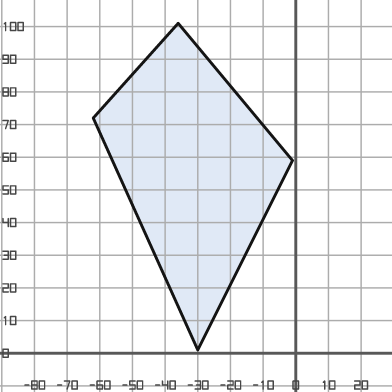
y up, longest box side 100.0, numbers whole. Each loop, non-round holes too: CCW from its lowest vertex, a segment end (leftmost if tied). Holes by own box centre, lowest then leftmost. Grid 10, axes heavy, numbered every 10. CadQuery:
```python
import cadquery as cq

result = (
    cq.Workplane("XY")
    .moveTo(-30.0, 1.0)
    .lineTo(-1.0, 59.0)
    .lineTo(-36.0, 101.0)
    .lineTo(-62.0, 72.0)
    .close()
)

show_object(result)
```